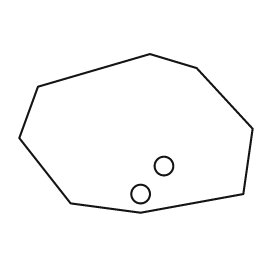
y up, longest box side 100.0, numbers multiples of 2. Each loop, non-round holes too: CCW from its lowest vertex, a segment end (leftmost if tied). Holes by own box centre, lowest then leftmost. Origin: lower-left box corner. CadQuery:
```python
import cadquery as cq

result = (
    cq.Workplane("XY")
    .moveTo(52.0, 0.0)
    .lineTo(96.0, 8.0)
    .lineTo(100.0, 36.0)
    .lineTo(76.0, 62.0)
    .lineTo(56.0, 68.0)
    .lineTo(8.0, 54.0)
    .lineTo(0.0, 32.0)
    .lineTo(22.0, 4.0)
    .close()
    .moveTo(52.0, 8.0)
    .circle(4.0)
    .moveTo(62.0, 20.0)
    .circle(4.0)
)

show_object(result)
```